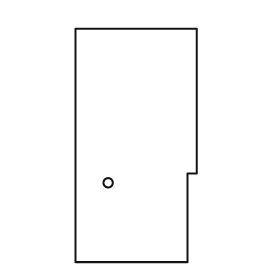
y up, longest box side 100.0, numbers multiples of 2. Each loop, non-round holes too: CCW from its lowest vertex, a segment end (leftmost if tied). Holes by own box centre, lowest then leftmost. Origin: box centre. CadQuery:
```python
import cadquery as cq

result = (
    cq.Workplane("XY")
    .moveTo(-26.0, -50.0)
    .lineTo(22.0, -50.0)
    .lineTo(22.0, -12.0)
    .lineTo(26.0, -12.0)
    .lineTo(26.0, 50.0)
    .lineTo(-26.0, 50.0)
    .close()
    .moveTo(-12.0, -16.0)
    .circle(2.0)
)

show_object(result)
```